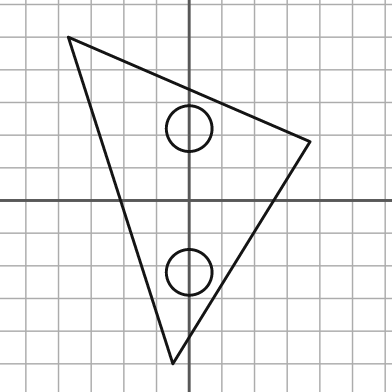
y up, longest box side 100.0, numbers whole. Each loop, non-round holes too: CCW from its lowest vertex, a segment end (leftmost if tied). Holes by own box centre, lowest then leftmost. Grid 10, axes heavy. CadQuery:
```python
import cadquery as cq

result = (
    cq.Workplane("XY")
    .moveTo(-5.0, -50.0)
    .lineTo(37.0, 18.0)
    .lineTo(-37.0, 50.0)
    .close()
    .moveTo(0.0, -22.0)
    .circle(7.0)
    .moveTo(0.0, 22.0)
    .circle(7.0)
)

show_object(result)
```